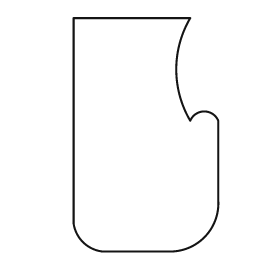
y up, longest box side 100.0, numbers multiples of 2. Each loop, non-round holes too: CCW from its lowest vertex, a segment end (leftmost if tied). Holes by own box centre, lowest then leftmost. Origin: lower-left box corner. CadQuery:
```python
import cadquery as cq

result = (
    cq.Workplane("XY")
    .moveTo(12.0, 0.0)
    .lineTo(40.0, 0.0)
    .threePointArc((56.0, 6.0), (62.0, 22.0))
    .lineTo(62.0, 56.0)
    .threePointArc((56.0, 60.0), (50.0, 56.0))
    .threePointArc((44.0, 78.0), (50.0, 100.0))
    .lineTo(0.0, 100.0)
    .lineTo(0.0, 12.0)
    .threePointArc((4.0, 4.0), (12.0, 0.0))
    .close()
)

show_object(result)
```